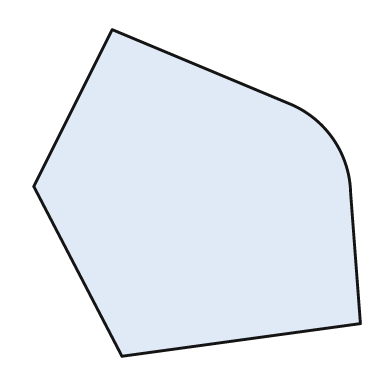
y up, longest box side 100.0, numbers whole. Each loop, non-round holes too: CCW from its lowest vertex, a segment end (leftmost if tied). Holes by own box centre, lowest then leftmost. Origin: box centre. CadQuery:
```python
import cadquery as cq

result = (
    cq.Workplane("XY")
    .moveTo(-23.0, -50.0)
    .lineTo(50.0, -40.0)
    .lineTo(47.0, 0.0)
    .threePointArc((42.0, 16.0), (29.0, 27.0))
    .lineTo(-26.0, 50.0)
    .lineTo(-50.0, 2.0)
    .close()
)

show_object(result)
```